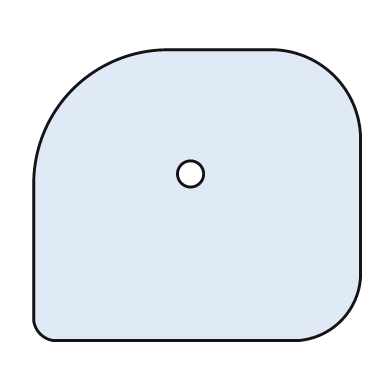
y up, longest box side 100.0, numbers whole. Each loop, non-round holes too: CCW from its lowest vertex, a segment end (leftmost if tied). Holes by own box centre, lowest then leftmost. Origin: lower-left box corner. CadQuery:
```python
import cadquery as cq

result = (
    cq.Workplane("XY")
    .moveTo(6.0, 0.0)
    .lineTo(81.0, 0.0)
    .threePointArc((94.0, 6.0), (100.0, 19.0))
    .lineTo(100.0, 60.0)
    .threePointArc((92.0, 81.0), (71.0, 89.0))
    .lineTo(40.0, 89.0)
    .threePointArc((12.0, 77.0), (0.0, 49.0))
    .lineTo(0.0, 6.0)
    .threePointArc((2.0, 2.0), (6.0, 0.0))
    .close()
    .moveTo(48.0, 51.0)
    .circle(4.0)
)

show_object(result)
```